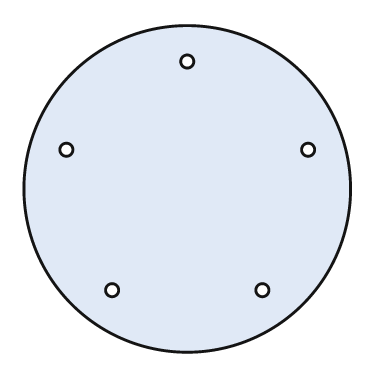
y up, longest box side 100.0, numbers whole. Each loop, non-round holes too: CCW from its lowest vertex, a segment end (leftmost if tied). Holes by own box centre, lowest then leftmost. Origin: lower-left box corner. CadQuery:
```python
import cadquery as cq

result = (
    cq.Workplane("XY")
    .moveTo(50.0, 50.0)
    .circle(50.0)
    .moveTo(27.0, 19.0)
    .circle(2.0)
    .moveTo(73.0, 19.0)
    .circle(2.0)
    .moveTo(13.0, 62.0)
    .circle(2.0)
    .moveTo(87.0, 62.0)
    .circle(2.0)
    .moveTo(50.0, 89.0)
    .circle(2.0)
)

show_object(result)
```